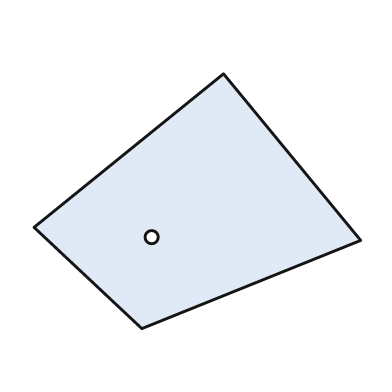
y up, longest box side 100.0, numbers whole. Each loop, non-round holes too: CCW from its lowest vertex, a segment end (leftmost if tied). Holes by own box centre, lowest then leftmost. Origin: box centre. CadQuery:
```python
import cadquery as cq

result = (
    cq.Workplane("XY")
    .moveTo(-17.0, -39.0)
    .lineTo(50.0, -12.0)
    .lineTo(8.0, 39.0)
    .lineTo(-50.0, -8.0)
    .close()
    .moveTo(-14.0, -11.0)
    .circle(2.0)
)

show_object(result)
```